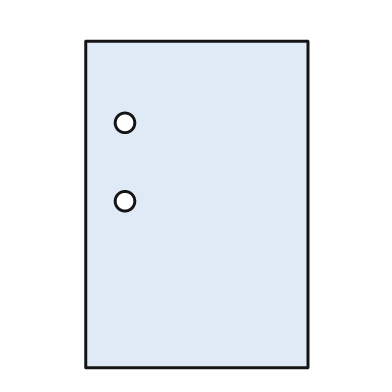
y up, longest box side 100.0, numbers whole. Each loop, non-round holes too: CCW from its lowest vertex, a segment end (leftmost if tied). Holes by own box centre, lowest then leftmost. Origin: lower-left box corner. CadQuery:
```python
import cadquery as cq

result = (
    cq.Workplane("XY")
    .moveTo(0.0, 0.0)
    .lineTo(68.0, 0.0)
    .lineTo(68.0, 100.0)
    .lineTo(0.0, 100.0)
    .close()
    .moveTo(12.0, 51.0)
    .circle(3.0)
    .moveTo(12.0, 75.0)
    .circle(3.0)
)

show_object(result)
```